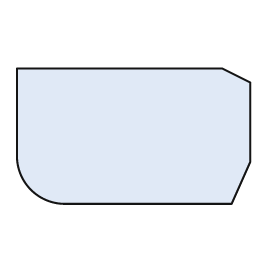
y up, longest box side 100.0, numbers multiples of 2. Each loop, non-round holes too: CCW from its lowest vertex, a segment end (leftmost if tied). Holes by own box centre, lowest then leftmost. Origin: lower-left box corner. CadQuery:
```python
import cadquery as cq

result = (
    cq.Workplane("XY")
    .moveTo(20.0, 0.0)
    .lineTo(92.0, 0.0)
    .lineTo(100.0, 18.0)
    .lineTo(100.0, 52.0)
    .lineTo(88.0, 58.0)
    .lineTo(0.0, 58.0)
    .lineTo(0.0, 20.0)
    .threePointArc((6.0, 6.0), (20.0, 0.0))
    .close()
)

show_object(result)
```